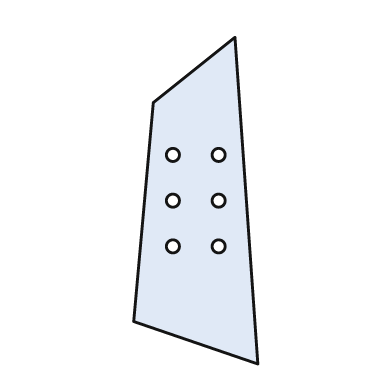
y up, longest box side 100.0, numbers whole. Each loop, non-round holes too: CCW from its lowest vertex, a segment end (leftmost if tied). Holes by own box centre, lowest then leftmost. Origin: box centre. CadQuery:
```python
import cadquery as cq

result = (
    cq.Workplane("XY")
    .moveTo(19.0, -50.0)
    .lineTo(12.0, 50.0)
    .lineTo(-13.0, 30.0)
    .lineTo(-19.0, -37.0)
    .close()
    .moveTo(-7.0, -14.0)
    .circle(2.0)
    .moveTo(7.0, -14.0)
    .circle(2.0)
    .moveTo(-7.0, 0.0)
    .circle(2.0)
    .moveTo(7.0, 0.0)
    .circle(2.0)
    .moveTo(-7.0, 14.0)
    .circle(2.0)
    .moveTo(7.0, 14.0)
    .circle(2.0)
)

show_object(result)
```